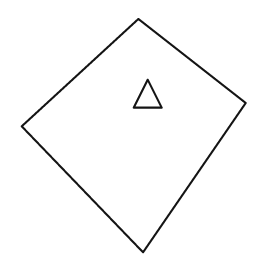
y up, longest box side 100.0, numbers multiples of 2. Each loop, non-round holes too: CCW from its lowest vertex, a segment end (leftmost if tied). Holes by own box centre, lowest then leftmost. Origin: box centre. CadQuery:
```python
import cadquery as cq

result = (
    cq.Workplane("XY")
    .moveTo(4.0, -50.0)
    .lineTo(48.0, 14.0)
    .lineTo(2.0, 50.0)
    .lineTo(-48.0, 4.0)
    .close()
    .moveTo(0.0, 12.0)
    .lineTo(12.0, 12.0)
    .lineTo(6.0, 24.0)
    .close()
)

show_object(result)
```